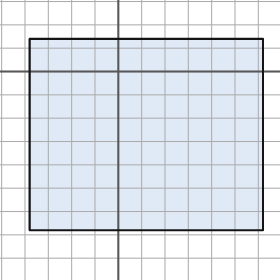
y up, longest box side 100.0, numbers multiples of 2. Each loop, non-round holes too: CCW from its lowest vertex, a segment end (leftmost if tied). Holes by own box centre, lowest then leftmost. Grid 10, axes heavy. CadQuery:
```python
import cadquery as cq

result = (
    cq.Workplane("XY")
    .moveTo(-38.0, -68.0)
    .lineTo(62.0, -68.0)
    .lineTo(62.0, 14.0)
    .lineTo(-38.0, 14.0)
    .close()
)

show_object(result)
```